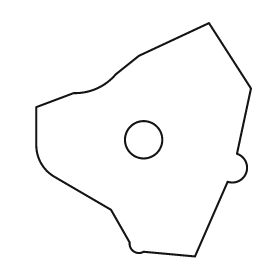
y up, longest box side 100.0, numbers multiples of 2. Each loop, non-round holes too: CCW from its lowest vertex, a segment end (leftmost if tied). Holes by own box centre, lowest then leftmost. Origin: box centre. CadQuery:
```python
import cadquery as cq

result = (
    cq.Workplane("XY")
    .moveTo(22.0, -50.0)
    .lineTo(36.0, -18.0)
    .threePointArc((44.0, -14.0), (40.0, -6.0))
    .lineTo(46.0, 22.0)
    .lineTo(28.0, 50.0)
    .lineTo(-2.0, 36.0)
    .lineTo(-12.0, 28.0)
    .threePointArc((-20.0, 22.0), (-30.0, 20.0))
    .lineTo(-46.0, 14.0)
    .lineTo(-46.0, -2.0)
    .threePointArc((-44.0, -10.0), (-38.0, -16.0))
    .lineTo(-14.0, -30.0)
    .lineTo(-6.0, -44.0)
    .threePointArc((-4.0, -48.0), (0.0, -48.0))
    .close()
    .moveTo(0.0, 0.0)
    .circle(8.0)
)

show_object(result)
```